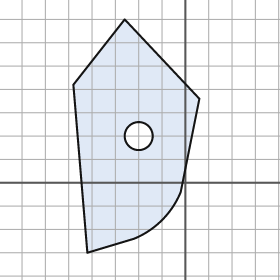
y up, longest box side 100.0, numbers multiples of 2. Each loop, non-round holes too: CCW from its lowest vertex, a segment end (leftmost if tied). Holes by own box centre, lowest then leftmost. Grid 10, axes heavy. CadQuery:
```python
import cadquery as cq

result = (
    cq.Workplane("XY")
    .moveTo(-42.0, -30.0)
    .lineTo(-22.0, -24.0)
    .threePointArc((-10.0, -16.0), (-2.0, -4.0))
    .lineTo(6.0, 36.0)
    .lineTo(-26.0, 70.0)
    .lineTo(-48.0, 42.0)
    .close()
    .moveTo(-20.0, 20.0)
    .circle(6.0)
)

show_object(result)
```